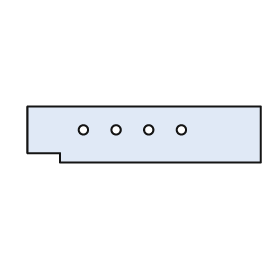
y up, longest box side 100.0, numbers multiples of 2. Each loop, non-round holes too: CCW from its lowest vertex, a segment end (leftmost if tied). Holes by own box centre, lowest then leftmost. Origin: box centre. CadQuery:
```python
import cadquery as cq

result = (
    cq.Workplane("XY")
    .moveTo(-36.0, -12.0)
    .lineTo(50.0, -12.0)
    .lineTo(50.0, 12.0)
    .lineTo(-50.0, 12.0)
    .lineTo(-50.0, -8.0)
    .lineTo(-36.0, -8.0)
    .close()
    .moveTo(-26.0, 2.0)
    .circle(2.0)
    .moveTo(-12.0, 2.0)
    .circle(2.0)
    .moveTo(2.0, 2.0)
    .circle(2.0)
    .moveTo(16.0, 2.0)
    .circle(2.0)
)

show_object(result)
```